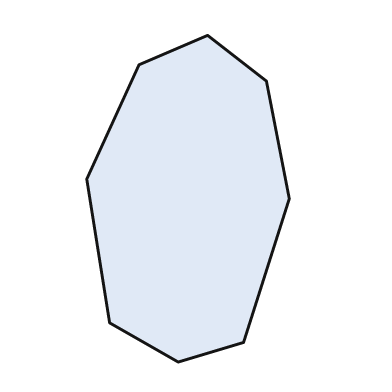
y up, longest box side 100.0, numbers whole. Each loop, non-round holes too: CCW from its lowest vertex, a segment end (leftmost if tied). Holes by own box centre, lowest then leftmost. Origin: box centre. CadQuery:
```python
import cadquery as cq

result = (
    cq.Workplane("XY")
    .moveTo(-3.0, -50.0)
    .lineTo(17.0, -44.0)
    .lineTo(31.0, 0.0)
    .lineTo(24.0, 36.0)
    .lineTo(6.0, 50.0)
    .lineTo(-15.0, 41.0)
    .lineTo(-31.0, 6.0)
    .lineTo(-24.0, -38.0)
    .close()
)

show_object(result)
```